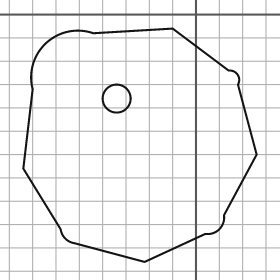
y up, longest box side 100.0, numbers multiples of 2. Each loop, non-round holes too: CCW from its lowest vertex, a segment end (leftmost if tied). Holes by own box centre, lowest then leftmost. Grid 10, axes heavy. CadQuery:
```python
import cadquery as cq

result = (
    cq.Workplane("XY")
    .moveTo(-22.0, -106.0)
    .lineTo(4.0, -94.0)
    .threePointArc((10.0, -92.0), (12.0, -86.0))
    .lineTo(26.0, -60.0)
    .lineTo(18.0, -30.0)
    .threePointArc((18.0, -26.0), (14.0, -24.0))
    .lineTo(-10.0, -6.0)
    .lineTo(-44.0, -8.0)
    .threePointArc((-64.0, -12.0), (-70.0, -32.0))
    .lineTo(-74.0, -66.0)
    .lineTo(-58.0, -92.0)
    .threePointArc((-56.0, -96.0), (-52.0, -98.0))
    .close()
    .moveTo(-34.0, -36.0)
    .circle(6.0)
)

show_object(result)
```